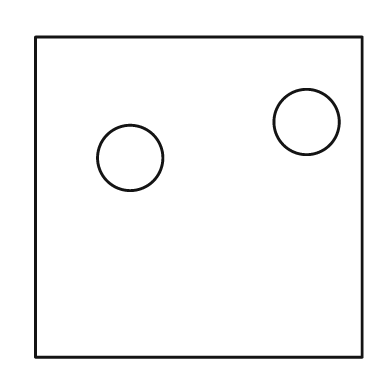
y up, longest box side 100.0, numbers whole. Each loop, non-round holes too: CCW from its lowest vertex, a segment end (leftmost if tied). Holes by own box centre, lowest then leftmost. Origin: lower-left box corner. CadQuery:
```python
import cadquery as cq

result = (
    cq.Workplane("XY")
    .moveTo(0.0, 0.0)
    .lineTo(100.0, 0.0)
    .lineTo(100.0, 98.0)
    .lineTo(0.0, 98.0)
    .close()
    .moveTo(29.0, 61.0)
    .circle(10.0)
    .moveTo(83.0, 72.0)
    .circle(10.0)
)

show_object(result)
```